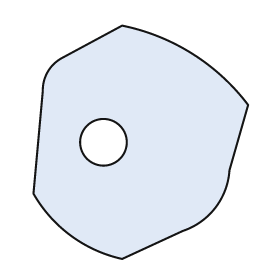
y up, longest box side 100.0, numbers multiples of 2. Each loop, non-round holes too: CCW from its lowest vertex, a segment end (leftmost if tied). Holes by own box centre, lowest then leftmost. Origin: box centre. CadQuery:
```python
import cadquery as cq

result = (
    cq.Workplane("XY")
    .moveTo(-8.0, -50.0)
    .lineTo(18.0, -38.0)
    .threePointArc((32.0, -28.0), (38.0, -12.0))
    .lineTo(46.0, 16.0)
    .threePointArc((22.0, 38.0), (-8.0, 50.0))
    .lineTo(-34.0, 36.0)
    .threePointArc((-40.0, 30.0), (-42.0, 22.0))
    .lineTo(-46.0, -22.0)
    .threePointArc((-30.0, -40.0), (-8.0, -50.0))
    .close()
    .moveTo(-16.0, 0.0)
    .circle(10.0)
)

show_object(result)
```